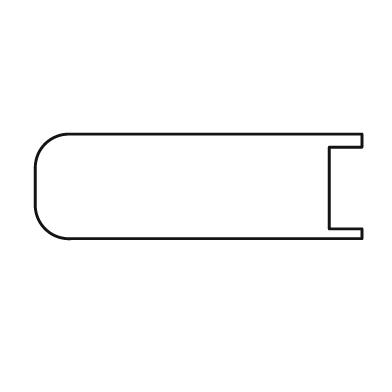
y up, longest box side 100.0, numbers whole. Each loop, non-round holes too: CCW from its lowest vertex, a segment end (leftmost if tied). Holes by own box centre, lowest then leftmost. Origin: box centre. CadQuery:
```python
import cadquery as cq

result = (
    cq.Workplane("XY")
    .moveTo(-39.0, -16.0)
    .lineTo(50.0, -16.0)
    .lineTo(50.0, -13.0)
    .lineTo(40.0, -13.0)
    .lineTo(40.0, 12.0)
    .lineTo(50.0, 12.0)
    .lineTo(50.0, 16.0)
    .lineTo(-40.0, 16.0)
    .threePointArc((-47.0, 13.0), (-50.0, 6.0))
    .lineTo(-50.0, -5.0)
    .threePointArc((-47.0, -13.0), (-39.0, -16.0))
    .close()
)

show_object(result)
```